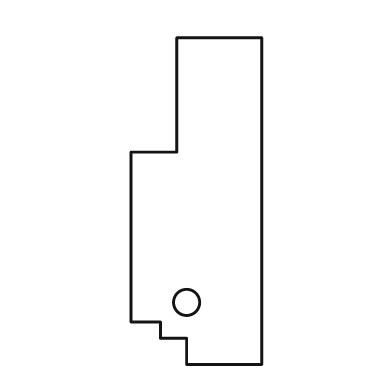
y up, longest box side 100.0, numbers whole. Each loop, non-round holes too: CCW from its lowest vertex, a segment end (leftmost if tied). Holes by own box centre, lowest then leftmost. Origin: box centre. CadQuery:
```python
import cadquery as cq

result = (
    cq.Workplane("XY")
    .moveTo(-3.0, -50.0)
    .lineTo(20.0, -50.0)
    .lineTo(20.0, 50.0)
    .lineTo(-6.0, 50.0)
    .lineTo(-6.0, 15.0)
    .lineTo(-20.0, 15.0)
    .lineTo(-20.0, -37.0)
    .lineTo(-11.0, -37.0)
    .lineTo(-11.0, -42.0)
    .lineTo(-3.0, -42.0)
    .close()
    .moveTo(-3.0, -31.0)
    .circle(4.0)
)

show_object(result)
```